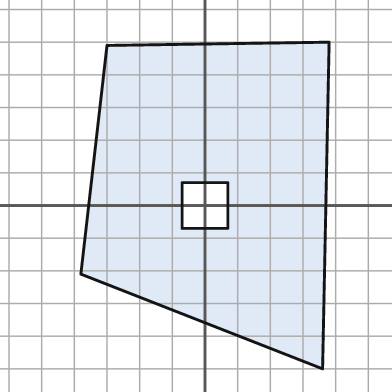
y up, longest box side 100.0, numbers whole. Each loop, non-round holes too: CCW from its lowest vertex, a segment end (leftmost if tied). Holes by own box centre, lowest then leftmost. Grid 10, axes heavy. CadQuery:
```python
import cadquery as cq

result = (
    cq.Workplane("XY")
    .moveTo(36.0, -50.0)
    .lineTo(38.0, 50.0)
    .lineTo(-30.0, 49.0)
    .lineTo(-38.0, -21.0)
    .close()
    .moveTo(-7.0, -7.0)
    .lineTo(7.0, -7.0)
    .lineTo(7.0, 7.0)
    .lineTo(-7.0, 7.0)
    .close()
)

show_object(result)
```